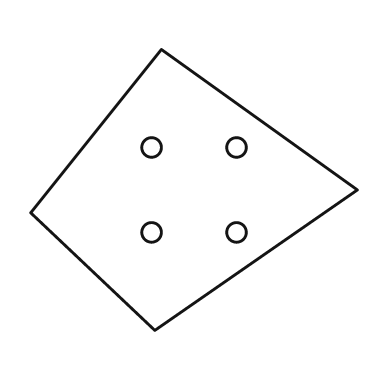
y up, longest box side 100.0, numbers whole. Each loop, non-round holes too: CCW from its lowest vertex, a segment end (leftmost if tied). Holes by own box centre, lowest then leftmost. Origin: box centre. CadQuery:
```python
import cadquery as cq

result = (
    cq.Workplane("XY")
    .moveTo(-12.0, -43.0)
    .lineTo(50.0, 0.0)
    .lineTo(-10.0, 43.0)
    .lineTo(-50.0, -7.0)
    .close()
    .moveTo(-13.0, -13.0)
    .circle(3.0)
    .moveTo(13.0, -13.0)
    .circle(3.0)
    .moveTo(-13.0, 13.0)
    .circle(3.0)
    .moveTo(13.0, 13.0)
    .circle(3.0)
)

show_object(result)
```